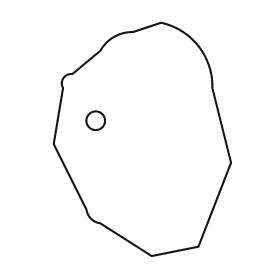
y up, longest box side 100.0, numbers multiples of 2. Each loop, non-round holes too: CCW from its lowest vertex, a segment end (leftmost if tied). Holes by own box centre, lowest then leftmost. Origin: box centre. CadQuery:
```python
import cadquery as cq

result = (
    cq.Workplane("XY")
    .moveTo(4.0, -50.0)
    .lineTo(24.0, -46.0)
    .lineTo(38.0, -10.0)
    .lineTo(30.0, 22.0)
    .threePointArc((24.0, 40.0), (8.0, 50.0))
    .lineTo(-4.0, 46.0)
    .threePointArc((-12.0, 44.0), (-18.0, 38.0))
    .lineTo(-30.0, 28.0)
    .threePointArc((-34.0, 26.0), (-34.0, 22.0))
    .lineTo(-38.0, -2.0)
    .lineTo(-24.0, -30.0)
    .threePointArc((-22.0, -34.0), (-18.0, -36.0))
    .close()
    .moveTo(-20.0, 8.0)
    .circle(4.0)
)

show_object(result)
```